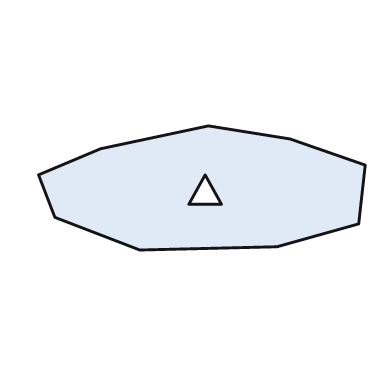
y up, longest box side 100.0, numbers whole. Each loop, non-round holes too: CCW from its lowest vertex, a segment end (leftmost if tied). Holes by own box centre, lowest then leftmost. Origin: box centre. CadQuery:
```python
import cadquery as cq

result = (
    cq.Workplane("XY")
    .moveTo(-19.0, -19.0)
    .lineTo(23.0, -18.0)
    .lineTo(48.0, -11.0)
    .lineTo(50.0, 7.0)
    .lineTo(27.0, 15.0)
    .lineTo(2.0, 19.0)
    .lineTo(-31.0, 12.0)
    .lineTo(-50.0, 4.0)
    .lineTo(-45.0, -9.0)
    .close()
    .moveTo(-4.0, -5.0)
    .lineTo(6.0, -5.0)
    .lineTo(1.0, 4.0)
    .close()
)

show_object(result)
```